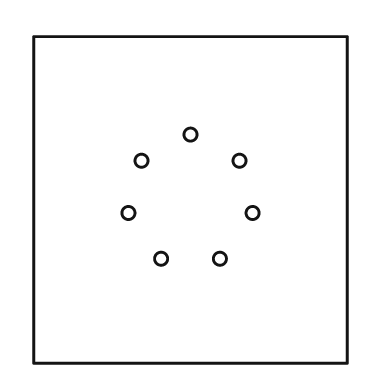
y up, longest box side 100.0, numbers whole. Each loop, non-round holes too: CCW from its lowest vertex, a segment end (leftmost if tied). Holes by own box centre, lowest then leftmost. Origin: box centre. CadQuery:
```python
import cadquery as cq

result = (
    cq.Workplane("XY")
    .moveTo(-48.0, -50.0)
    .lineTo(48.0, -50.0)
    .lineTo(48.0, 50.0)
    .lineTo(-48.0, 50.0)
    .close()
    .moveTo(-9.0, -18.0)
    .circle(2.0)
    .moveTo(9.0, -18.0)
    .circle(2.0)
    .moveTo(-19.0, -4.0)
    .circle(2.0)
    .moveTo(19.0, -4.0)
    .circle(2.0)
    .moveTo(-15.0, 12.0)
    .circle(2.0)
    .moveTo(15.0, 12.0)
    .circle(2.0)
    .moveTo(0.0, 20.0)
    .circle(2.0)
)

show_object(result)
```